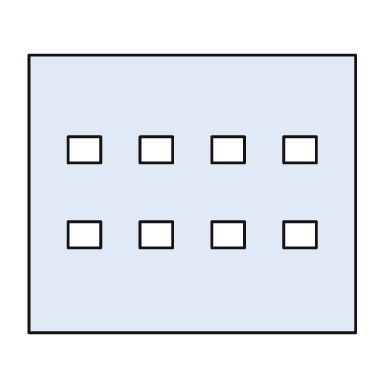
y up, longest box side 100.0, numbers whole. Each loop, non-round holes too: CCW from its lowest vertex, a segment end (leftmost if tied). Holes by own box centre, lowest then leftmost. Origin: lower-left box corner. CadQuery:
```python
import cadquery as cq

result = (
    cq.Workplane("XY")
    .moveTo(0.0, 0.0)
    .lineTo(100.0, 0.0)
    .lineTo(100.0, 85.0)
    .lineTo(0.0, 85.0)
    .close()
    .moveTo(12.0, 26.0)
    .lineTo(22.0, 26.0)
    .lineTo(22.0, 34.0)
    .lineTo(12.0, 34.0)
    .close()
    .moveTo(34.0, 26.0)
    .lineTo(44.0, 26.0)
    .lineTo(44.0, 34.0)
    .lineTo(34.0, 34.0)
    .close()
    .moveTo(56.0, 26.0)
    .lineTo(66.0, 26.0)
    .lineTo(66.0, 34.0)
    .lineTo(56.0, 34.0)
    .close()
    .moveTo(78.0, 26.0)
    .lineTo(88.0, 26.0)
    .lineTo(88.0, 34.0)
    .lineTo(78.0, 34.0)
    .close()
    .moveTo(12.0, 52.0)
    .lineTo(22.0, 52.0)
    .lineTo(22.0, 60.0)
    .lineTo(12.0, 60.0)
    .close()
    .moveTo(34.0, 52.0)
    .lineTo(44.0, 52.0)
    .lineTo(44.0, 60.0)
    .lineTo(34.0, 60.0)
    .close()
    .moveTo(56.0, 52.0)
    .lineTo(66.0, 52.0)
    .lineTo(66.0, 60.0)
    .lineTo(56.0, 60.0)
    .close()
    .moveTo(78.0, 52.0)
    .lineTo(88.0, 52.0)
    .lineTo(88.0, 60.0)
    .lineTo(78.0, 60.0)
    .close()
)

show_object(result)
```